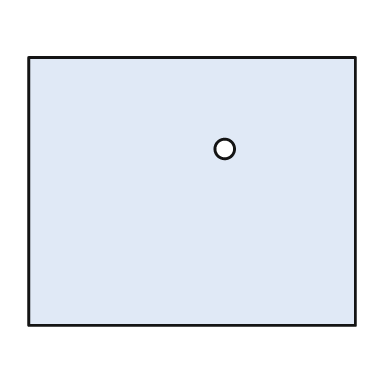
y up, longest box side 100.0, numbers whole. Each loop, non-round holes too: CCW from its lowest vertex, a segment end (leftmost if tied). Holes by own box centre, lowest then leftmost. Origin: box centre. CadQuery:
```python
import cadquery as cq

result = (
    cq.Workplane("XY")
    .moveTo(-50.0, -41.0)
    .lineTo(50.0, -41.0)
    .lineTo(50.0, 41.0)
    .lineTo(-50.0, 41.0)
    .close()
    .moveTo(10.0, 13.0)
    .circle(3.0)
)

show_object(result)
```